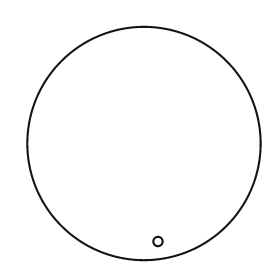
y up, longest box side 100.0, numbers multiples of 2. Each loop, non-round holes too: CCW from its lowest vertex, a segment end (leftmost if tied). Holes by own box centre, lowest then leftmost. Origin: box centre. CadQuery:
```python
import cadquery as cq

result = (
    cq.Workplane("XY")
    .moveTo(0.0, 0.0)
    .circle(50.0)
    .moveTo(6.0, -42.0)
    .circle(2.0)
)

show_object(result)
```